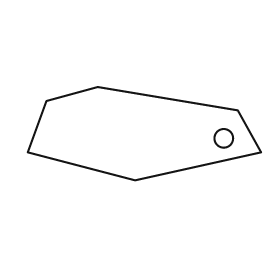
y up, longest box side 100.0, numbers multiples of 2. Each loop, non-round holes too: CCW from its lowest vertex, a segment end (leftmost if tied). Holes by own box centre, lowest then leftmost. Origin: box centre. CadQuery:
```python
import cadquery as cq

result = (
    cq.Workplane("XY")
    .moveTo(-4.0, -20.0)
    .lineTo(50.0, -8.0)
    .lineTo(40.0, 10.0)
    .lineTo(-20.0, 20.0)
    .lineTo(-42.0, 14.0)
    .lineTo(-50.0, -8.0)
    .close()
    .moveTo(34.0, -2.0)
    .circle(4.0)
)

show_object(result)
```